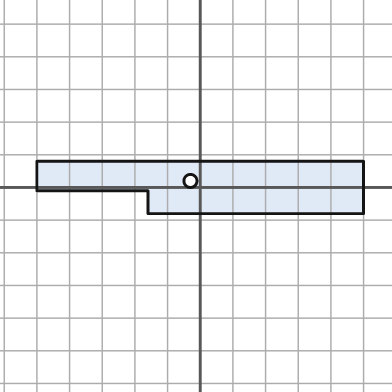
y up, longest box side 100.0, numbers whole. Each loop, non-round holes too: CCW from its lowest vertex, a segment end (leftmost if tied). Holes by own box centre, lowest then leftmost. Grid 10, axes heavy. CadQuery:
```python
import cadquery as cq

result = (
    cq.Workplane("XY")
    .moveTo(-16.0, -8.0)
    .lineTo(50.0, -8.0)
    .lineTo(50.0, 8.0)
    .lineTo(-50.0, 8.0)
    .lineTo(-50.0, -1.0)
    .lineTo(-16.0, -1.0)
    .close()
    .moveTo(-3.0, 2.0)
    .circle(2.0)
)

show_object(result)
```